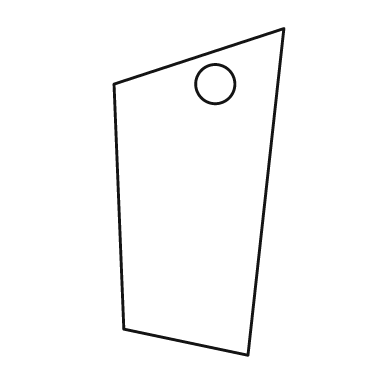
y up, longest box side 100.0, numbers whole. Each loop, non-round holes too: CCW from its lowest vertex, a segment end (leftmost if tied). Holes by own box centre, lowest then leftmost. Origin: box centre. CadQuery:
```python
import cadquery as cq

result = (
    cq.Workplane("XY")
    .moveTo(15.0, -50.0)
    .lineTo(26.0, 50.0)
    .lineTo(-26.0, 33.0)
    .lineTo(-23.0, -42.0)
    .close()
    .moveTo(5.0, 33.0)
    .circle(6.0)
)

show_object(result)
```